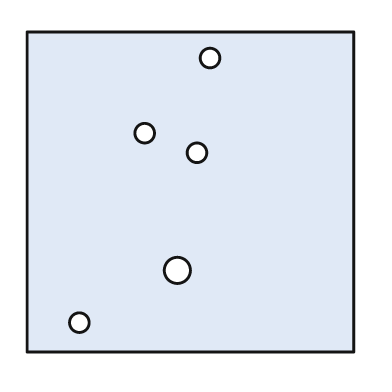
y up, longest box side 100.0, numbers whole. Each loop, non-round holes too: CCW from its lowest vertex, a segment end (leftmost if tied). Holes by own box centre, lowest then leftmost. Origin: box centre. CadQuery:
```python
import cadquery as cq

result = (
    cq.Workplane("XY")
    .moveTo(-50.0, -49.0)
    .lineTo(50.0, -49.0)
    .lineTo(50.0, 49.0)
    .lineTo(-50.0, 49.0)
    .close()
    .moveTo(-34.0, -40.0)
    .circle(3.0)
    .moveTo(-4.0, -24.0)
    .circle(4.0)
    .moveTo(2.0, 12.0)
    .circle(3.0)
    .moveTo(-14.0, 18.0)
    .circle(3.0)
    .moveTo(6.0, 41.0)
    .circle(3.0)
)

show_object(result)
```